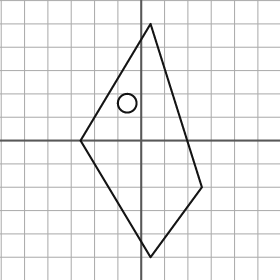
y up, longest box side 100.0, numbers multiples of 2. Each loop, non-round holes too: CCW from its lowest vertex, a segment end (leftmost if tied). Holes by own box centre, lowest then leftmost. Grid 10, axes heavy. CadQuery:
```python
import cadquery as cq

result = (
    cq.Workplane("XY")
    .moveTo(4.0, -50.0)
    .lineTo(26.0, -20.0)
    .lineTo(4.0, 50.0)
    .lineTo(-26.0, 0.0)
    .close()
    .moveTo(-6.0, 16.0)
    .circle(4.0)
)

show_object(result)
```